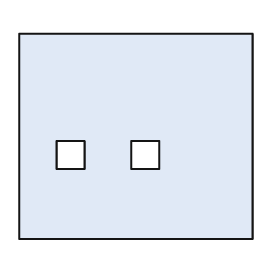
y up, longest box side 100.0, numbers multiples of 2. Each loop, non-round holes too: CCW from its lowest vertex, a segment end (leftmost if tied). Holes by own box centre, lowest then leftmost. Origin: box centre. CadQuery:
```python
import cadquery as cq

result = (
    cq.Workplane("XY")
    .moveTo(-50.0, -44.0)
    .lineTo(50.0, -44.0)
    .lineTo(50.0, 44.0)
    .lineTo(-50.0, 44.0)
    .close()
    .moveTo(-34.0, -14.0)
    .lineTo(-22.0, -14.0)
    .lineTo(-22.0, -2.0)
    .lineTo(-34.0, -2.0)
    .close()
    .moveTo(-2.0, -14.0)
    .lineTo(10.0, -14.0)
    .lineTo(10.0, -2.0)
    .lineTo(-2.0, -2.0)
    .close()
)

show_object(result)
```